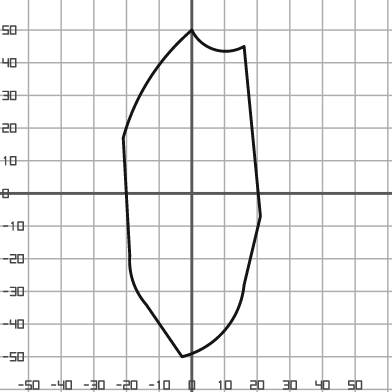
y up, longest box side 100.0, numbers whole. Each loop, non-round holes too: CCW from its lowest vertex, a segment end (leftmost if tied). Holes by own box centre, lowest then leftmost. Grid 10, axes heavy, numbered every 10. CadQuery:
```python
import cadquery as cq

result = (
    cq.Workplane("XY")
    .moveTo(-3.0, -50.0)
    .threePointArc((10.0, -42.0), (16.0, -28.0))
    .lineTo(21.0, -7.0)
    .lineTo(16.0, 45.0)
    .threePointArc((7.0, 44.0), (0.0, 50.0))
    .threePointArc((-13.0, 35.0), (-21.0, 17.0))
    .lineTo(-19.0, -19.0)
    .threePointArc((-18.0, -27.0), (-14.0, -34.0))
    .close()
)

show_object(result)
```